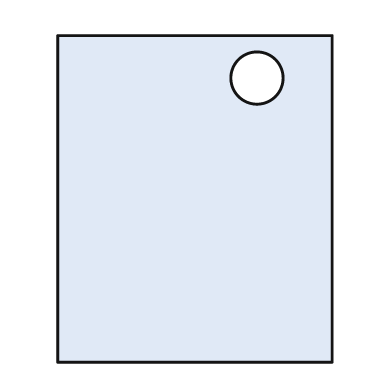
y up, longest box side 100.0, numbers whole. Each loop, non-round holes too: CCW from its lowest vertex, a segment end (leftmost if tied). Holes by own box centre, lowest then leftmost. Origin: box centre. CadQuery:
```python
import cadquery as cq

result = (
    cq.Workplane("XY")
    .moveTo(-42.0, -50.0)
    .lineTo(42.0, -50.0)
    .lineTo(42.0, 50.0)
    .lineTo(-42.0, 50.0)
    .close()
    .moveTo(19.0, 37.0)
    .circle(8.0)
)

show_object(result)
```